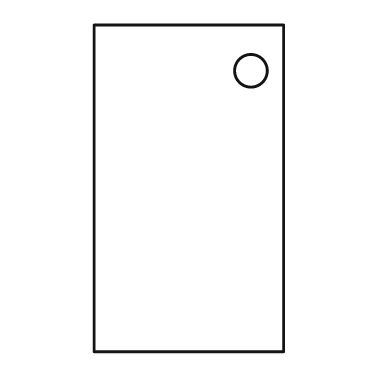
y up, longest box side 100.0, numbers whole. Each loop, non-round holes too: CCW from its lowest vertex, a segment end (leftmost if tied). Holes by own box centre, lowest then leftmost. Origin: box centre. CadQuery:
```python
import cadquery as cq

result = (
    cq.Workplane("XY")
    .moveTo(-29.0, -50.0)
    .lineTo(29.0, -50.0)
    .lineTo(29.0, 50.0)
    .lineTo(-29.0, 50.0)
    .close()
    .moveTo(19.0, 36.0)
    .circle(5.0)
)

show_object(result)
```